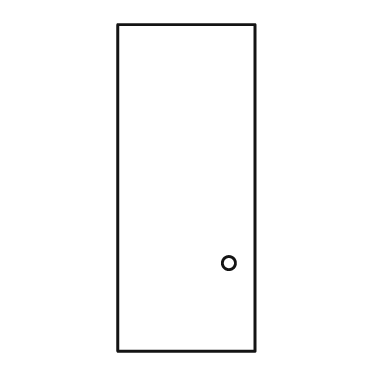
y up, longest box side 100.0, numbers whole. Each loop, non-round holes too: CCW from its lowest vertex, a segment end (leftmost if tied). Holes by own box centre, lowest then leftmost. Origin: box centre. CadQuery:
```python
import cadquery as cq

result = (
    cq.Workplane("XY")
    .moveTo(-21.0, -50.0)
    .lineTo(21.0, -50.0)
    .lineTo(21.0, 50.0)
    .lineTo(-21.0, 50.0)
    .close()
    .moveTo(13.0, -23.0)
    .circle(2.0)
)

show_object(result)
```